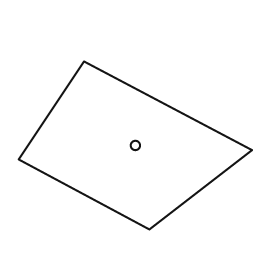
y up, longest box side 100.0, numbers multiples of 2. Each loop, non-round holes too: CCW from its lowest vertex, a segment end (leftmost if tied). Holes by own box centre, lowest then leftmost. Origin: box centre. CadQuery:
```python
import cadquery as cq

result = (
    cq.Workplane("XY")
    .moveTo(6.0, -36.0)
    .lineTo(50.0, -2.0)
    .lineTo(-22.0, 36.0)
    .lineTo(-50.0, -6.0)
    .close()
    .moveTo(0.0, 0.0)
    .circle(2.0)
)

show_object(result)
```